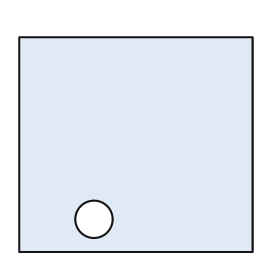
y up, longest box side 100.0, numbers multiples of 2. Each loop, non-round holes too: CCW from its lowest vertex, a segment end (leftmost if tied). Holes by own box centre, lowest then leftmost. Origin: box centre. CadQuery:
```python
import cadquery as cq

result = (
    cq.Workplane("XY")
    .moveTo(-50.0, -46.0)
    .lineTo(50.0, -46.0)
    .lineTo(50.0, 46.0)
    .lineTo(-50.0, 46.0)
    .close()
    .moveTo(-18.0, -32.0)
    .circle(8.0)
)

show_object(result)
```